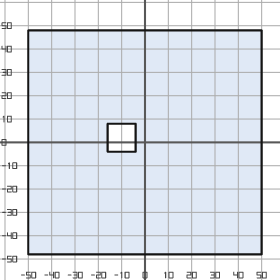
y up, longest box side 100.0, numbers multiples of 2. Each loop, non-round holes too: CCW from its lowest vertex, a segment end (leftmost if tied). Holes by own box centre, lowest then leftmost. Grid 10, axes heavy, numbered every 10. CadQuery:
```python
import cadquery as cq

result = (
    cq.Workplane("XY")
    .moveTo(-50.0, -48.0)
    .lineTo(50.0, -48.0)
    .lineTo(50.0, 48.0)
    .lineTo(-50.0, 48.0)
    .close()
    .moveTo(-16.0, -4.0)
    .lineTo(-4.0, -4.0)
    .lineTo(-4.0, 8.0)
    .lineTo(-16.0, 8.0)
    .close()
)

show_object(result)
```